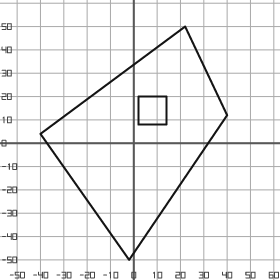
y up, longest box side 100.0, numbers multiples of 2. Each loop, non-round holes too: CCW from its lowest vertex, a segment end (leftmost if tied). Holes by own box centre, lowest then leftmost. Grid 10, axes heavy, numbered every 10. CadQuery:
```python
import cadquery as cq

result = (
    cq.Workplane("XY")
    .moveTo(-2.0, -50.0)
    .lineTo(40.0, 12.0)
    .lineTo(22.0, 50.0)
    .lineTo(-40.0, 4.0)
    .close()
    .moveTo(2.0, 8.0)
    .lineTo(14.0, 8.0)
    .lineTo(14.0, 20.0)
    .lineTo(2.0, 20.0)
    .close()
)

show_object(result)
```